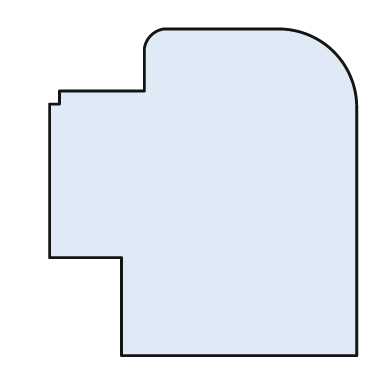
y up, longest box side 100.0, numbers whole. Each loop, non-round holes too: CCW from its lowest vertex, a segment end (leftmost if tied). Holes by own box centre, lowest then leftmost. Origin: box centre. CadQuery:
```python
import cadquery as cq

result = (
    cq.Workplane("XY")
    .moveTo(-25.0, -50.0)
    .lineTo(47.0, -50.0)
    .lineTo(47.0, 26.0)
    .threePointArc((40.0, 43.0), (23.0, 50.0))
    .lineTo(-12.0, 50.0)
    .threePointArc((-16.0, 48.0), (-18.0, 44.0))
    .lineTo(-18.0, 31.0)
    .lineTo(-44.0, 31.0)
    .lineTo(-44.0, 27.0)
    .lineTo(-47.0, 27.0)
    .lineTo(-47.0, -20.0)
    .lineTo(-25.0, -20.0)
    .close()
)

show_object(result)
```